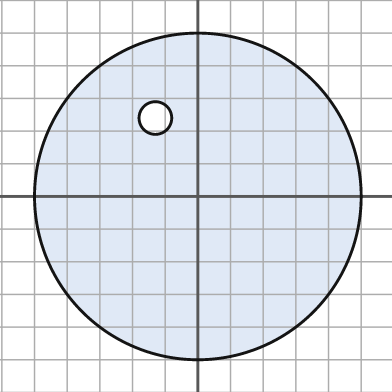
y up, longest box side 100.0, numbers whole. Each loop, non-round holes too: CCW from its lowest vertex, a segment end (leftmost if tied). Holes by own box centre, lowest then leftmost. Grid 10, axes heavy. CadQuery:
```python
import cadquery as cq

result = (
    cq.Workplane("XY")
    .moveTo(0.0, 0.0)
    .circle(50.0)
    .moveTo(-13.0, 24.0)
    .circle(5.0)
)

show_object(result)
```